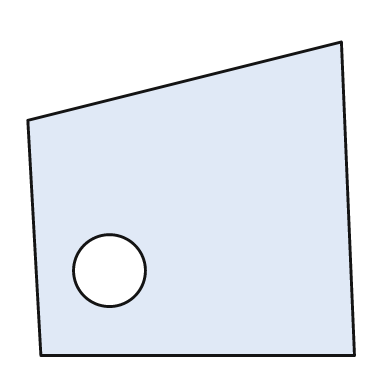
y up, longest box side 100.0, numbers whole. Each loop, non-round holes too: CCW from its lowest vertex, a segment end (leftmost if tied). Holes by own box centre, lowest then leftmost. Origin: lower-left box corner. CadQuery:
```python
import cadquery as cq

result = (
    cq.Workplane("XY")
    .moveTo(4.0, 0.0)
    .lineTo(100.0, 0.0)
    .lineTo(96.0, 96.0)
    .lineTo(0.0, 72.0)
    .close()
    .moveTo(25.0, 26.0)
    .circle(11.0)
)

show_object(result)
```